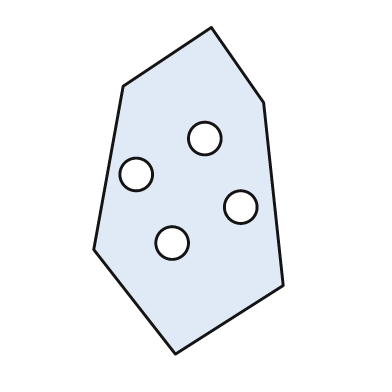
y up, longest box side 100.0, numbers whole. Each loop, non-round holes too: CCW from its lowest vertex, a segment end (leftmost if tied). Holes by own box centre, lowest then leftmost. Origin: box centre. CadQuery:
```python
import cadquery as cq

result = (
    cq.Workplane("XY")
    .moveTo(-4.0, -50.0)
    .lineTo(29.0, -29.0)
    .lineTo(23.0, 27.0)
    .lineTo(7.0, 50.0)
    .lineTo(-20.0, 32.0)
    .lineTo(-29.0, -18.0)
    .close()
    .moveTo(-5.0, -16.0)
    .circle(5.0)
    .moveTo(16.0, -5.0)
    .circle(5.0)
    .moveTo(-16.0, 5.0)
    .circle(5.0)
    .moveTo(5.0, 16.0)
    .circle(5.0)
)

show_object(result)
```